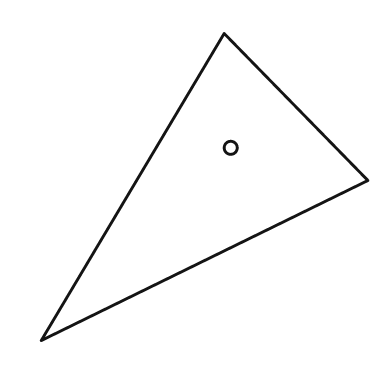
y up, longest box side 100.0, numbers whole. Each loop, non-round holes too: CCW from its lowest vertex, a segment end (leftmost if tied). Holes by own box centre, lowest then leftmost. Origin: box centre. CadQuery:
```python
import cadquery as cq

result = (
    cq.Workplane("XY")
    .moveTo(-50.0, -47.0)
    .lineTo(50.0, 2.0)
    .lineTo(6.0, 47.0)
    .close()
    .moveTo(8.0, 12.0)
    .circle(2.0)
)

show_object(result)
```